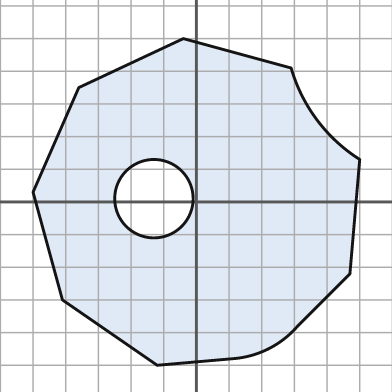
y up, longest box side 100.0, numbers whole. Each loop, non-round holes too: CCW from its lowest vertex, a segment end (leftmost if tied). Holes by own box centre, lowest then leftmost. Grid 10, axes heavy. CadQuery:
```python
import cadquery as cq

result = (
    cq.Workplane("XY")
    .moveTo(-12.0, -50.0)
    .lineTo(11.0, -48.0)
    .threePointArc((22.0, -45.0), (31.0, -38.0))
    .lineTo(47.0, -22.0)
    .lineTo(50.0, 13.0)
    .threePointArc((37.0, 25.0), (29.0, 41.0))
    .lineTo(-4.0, 50.0)
    .lineTo(-36.0, 35.0)
    .lineTo(-50.0, 3.0)
    .lineTo(-41.0, -30.0)
    .close()
    .moveTo(-13.0, 1.0)
    .circle(12.0)
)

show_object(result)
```